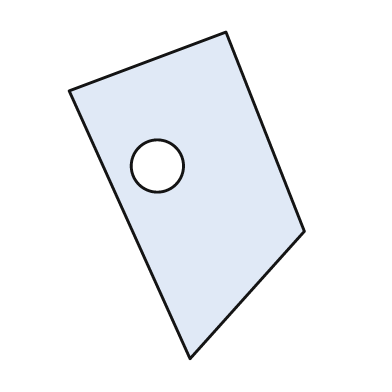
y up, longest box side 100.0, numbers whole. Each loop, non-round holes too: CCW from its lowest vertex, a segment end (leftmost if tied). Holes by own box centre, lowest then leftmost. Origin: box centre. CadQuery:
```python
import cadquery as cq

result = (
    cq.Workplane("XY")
    .moveTo(1.0, -50.0)
    .lineTo(36.0, -11.0)
    .lineTo(12.0, 50.0)
    .lineTo(-36.0, 32.0)
    .close()
    .moveTo(-9.0, 9.0)
    .circle(8.0)
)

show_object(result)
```